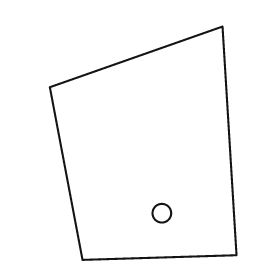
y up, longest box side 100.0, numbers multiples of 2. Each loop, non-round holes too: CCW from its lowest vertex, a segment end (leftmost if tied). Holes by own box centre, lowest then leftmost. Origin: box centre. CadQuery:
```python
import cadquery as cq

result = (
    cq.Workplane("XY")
    .moveTo(-26.0, -50.0)
    .lineTo(40.0, -48.0)
    .lineTo(34.0, 50.0)
    .lineTo(-40.0, 24.0)
    .close()
    .moveTo(8.0, -30.0)
    .circle(4.0)
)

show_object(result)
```